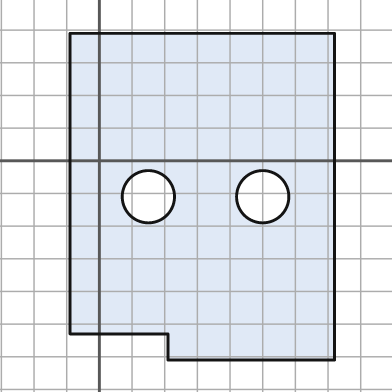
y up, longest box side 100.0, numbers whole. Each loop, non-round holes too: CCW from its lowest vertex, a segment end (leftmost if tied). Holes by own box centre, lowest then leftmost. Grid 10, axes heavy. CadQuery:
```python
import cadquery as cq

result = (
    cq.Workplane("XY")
    .moveTo(21.0, -61.0)
    .lineTo(72.0, -61.0)
    .lineTo(72.0, 39.0)
    .lineTo(-9.0, 39.0)
    .lineTo(-9.0, -53.0)
    .lineTo(21.0, -53.0)
    .close()
    .moveTo(15.0, -11.0)
    .circle(8.0)
    .moveTo(50.0, -11.0)
    .circle(8.0)
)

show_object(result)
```